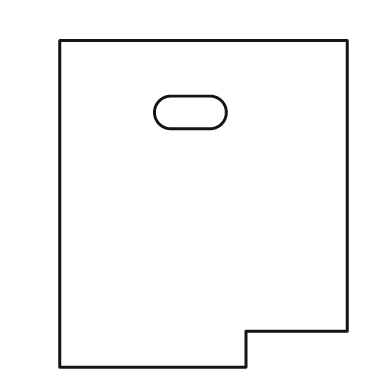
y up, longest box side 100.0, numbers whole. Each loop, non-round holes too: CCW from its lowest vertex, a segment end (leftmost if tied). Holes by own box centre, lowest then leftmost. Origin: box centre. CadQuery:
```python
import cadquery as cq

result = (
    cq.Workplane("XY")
    .moveTo(-44.0, -50.0)
    .lineTo(13.0, -50.0)
    .lineTo(13.0, -39.0)
    .lineTo(44.0, -39.0)
    .lineTo(44.0, 50.0)
    .lineTo(-44.0, 50.0)
    .close()
    .moveTo(-10.0, 23.0)
    .lineTo(2.0, 23.0)
    .threePointArc((7.0, 28.0), (2.0, 33.0))
    .lineTo(-10.0, 33.0)
    .threePointArc((-15.0, 28.0), (-10.0, 23.0))
    .close()
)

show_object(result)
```